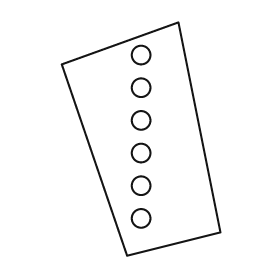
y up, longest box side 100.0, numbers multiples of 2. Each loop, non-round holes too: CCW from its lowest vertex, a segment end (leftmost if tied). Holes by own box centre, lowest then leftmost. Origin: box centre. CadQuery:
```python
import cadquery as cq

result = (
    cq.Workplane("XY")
    .moveTo(-6.0, -50.0)
    .lineTo(34.0, -40.0)
    .lineTo(16.0, 50.0)
    .lineTo(-34.0, 32.0)
    .close()
    .moveTo(0.0, -34.0)
    .circle(4.0)
    .moveTo(0.0, -20.0)
    .circle(4.0)
    .moveTo(0.0, -6.0)
    .circle(4.0)
    .moveTo(0.0, 8.0)
    .circle(4.0)
    .moveTo(0.0, 22.0)
    .circle(4.0)
    .moveTo(0.0, 36.0)
    .circle(4.0)
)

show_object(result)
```